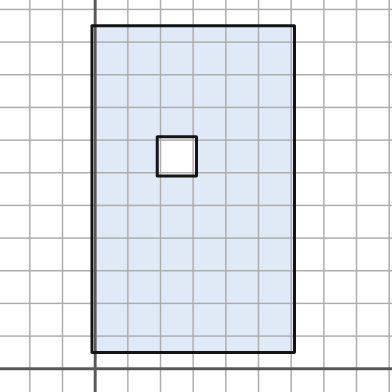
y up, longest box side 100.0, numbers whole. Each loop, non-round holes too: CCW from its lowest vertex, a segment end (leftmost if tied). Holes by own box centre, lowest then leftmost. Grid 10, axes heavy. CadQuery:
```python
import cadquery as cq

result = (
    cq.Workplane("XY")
    .moveTo(-1.0, 5.0)
    .lineTo(61.0, 5.0)
    .lineTo(61.0, 105.0)
    .lineTo(-1.0, 105.0)
    .close()
    .moveTo(19.0, 59.0)
    .lineTo(31.0, 59.0)
    .lineTo(31.0, 71.0)
    .lineTo(19.0, 71.0)
    .close()
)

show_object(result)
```